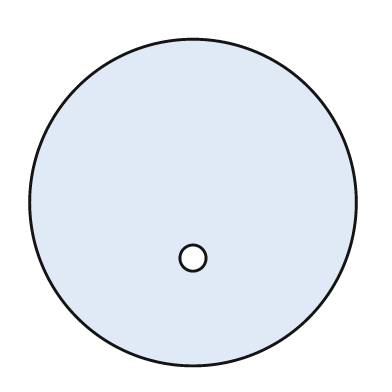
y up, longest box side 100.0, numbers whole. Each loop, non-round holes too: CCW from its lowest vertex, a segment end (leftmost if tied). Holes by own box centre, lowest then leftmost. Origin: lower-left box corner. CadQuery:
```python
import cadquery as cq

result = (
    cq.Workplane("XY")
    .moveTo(50.0, 50.0)
    .circle(50.0)
    .moveTo(50.0, 33.0)
    .circle(4.0)
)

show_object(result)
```